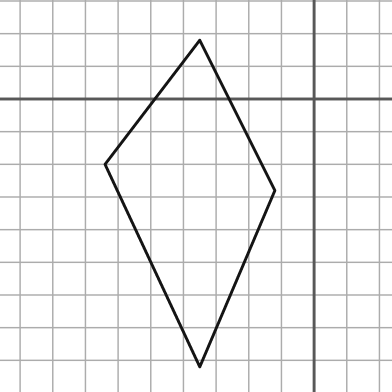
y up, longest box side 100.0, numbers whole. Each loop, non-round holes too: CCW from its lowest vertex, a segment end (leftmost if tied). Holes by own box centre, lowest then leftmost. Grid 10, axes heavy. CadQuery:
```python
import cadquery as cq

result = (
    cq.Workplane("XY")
    .moveTo(-35.0, -82.0)
    .lineTo(-12.0, -28.0)
    .lineTo(-35.0, 18.0)
    .lineTo(-64.0, -20.0)
    .close()
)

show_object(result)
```